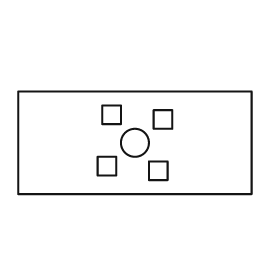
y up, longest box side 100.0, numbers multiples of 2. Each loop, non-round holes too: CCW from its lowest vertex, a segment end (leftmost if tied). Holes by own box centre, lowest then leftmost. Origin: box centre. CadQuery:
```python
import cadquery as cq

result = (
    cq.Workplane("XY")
    .moveTo(-50.0, -22.0)
    .lineTo(50.0, -22.0)
    .lineTo(50.0, 22.0)
    .lineTo(-50.0, 22.0)
    .close()
    .moveTo(6.0, -16.0)
    .lineTo(14.0, -16.0)
    .lineTo(14.0, -8.0)
    .lineTo(6.0, -8.0)
    .close()
    .moveTo(-16.0, -14.0)
    .lineTo(-8.0, -14.0)
    .lineTo(-8.0, -6.0)
    .lineTo(-16.0, -6.0)
    .close()
    .moveTo(0.0, 0.0)
    .circle(6.0)
    .moveTo(8.0, 6.0)
    .lineTo(16.0, 6.0)
    .lineTo(16.0, 14.0)
    .lineTo(8.0, 14.0)
    .close()
    .moveTo(-14.0, 8.0)
    .lineTo(-6.0, 8.0)
    .lineTo(-6.0, 16.0)
    .lineTo(-14.0, 16.0)
    .close()
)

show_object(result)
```